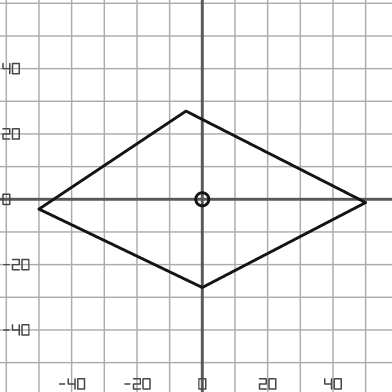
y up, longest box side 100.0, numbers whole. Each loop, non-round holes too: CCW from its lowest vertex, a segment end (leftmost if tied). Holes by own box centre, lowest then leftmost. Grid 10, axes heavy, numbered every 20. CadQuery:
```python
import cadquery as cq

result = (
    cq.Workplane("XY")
    .moveTo(0.0, -27.0)
    .lineTo(50.0, -1.0)
    .lineTo(-5.0, 27.0)
    .lineTo(-50.0, -3.0)
    .close()
    .moveTo(0.0, 0.0)
    .circle(2.0)
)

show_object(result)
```